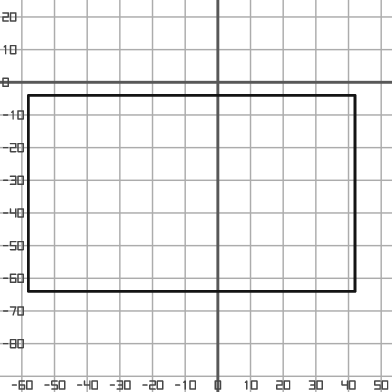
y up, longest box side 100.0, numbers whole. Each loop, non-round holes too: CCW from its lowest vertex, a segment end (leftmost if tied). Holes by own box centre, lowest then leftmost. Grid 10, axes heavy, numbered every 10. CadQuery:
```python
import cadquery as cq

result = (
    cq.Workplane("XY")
    .moveTo(-58.0, -64.0)
    .lineTo(42.0, -64.0)
    .lineTo(42.0, -4.0)
    .lineTo(-58.0, -4.0)
    .close()
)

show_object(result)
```